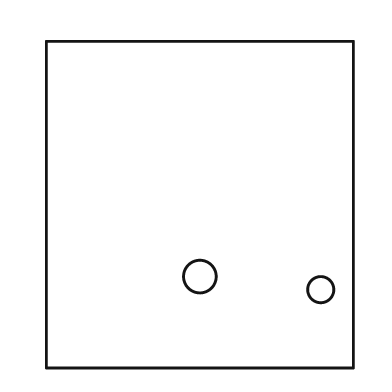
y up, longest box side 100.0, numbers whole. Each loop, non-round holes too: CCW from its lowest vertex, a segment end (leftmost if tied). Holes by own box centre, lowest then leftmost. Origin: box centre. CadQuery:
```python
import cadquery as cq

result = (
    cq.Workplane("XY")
    .moveTo(-47.0, -50.0)
    .lineTo(47.0, -50.0)
    .lineTo(47.0, 50.0)
    .lineTo(-47.0, 50.0)
    .close()
    .moveTo(37.0, -26.0)
    .circle(4.0)
    .moveTo(0.0, -22.0)
    .circle(5.0)
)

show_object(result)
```